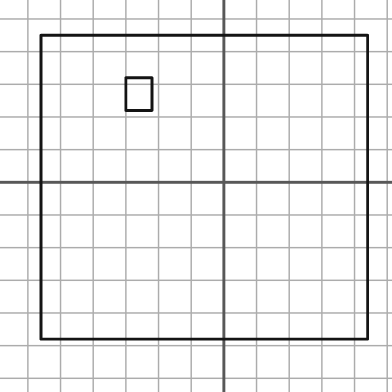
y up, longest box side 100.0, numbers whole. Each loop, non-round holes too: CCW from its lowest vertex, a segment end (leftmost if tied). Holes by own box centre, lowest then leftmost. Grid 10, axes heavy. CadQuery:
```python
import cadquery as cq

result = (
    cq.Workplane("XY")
    .moveTo(-56.0, -48.0)
    .lineTo(44.0, -48.0)
    .lineTo(44.0, 45.0)
    .lineTo(-56.0, 45.0)
    .close()
    .moveTo(-30.0, 22.0)
    .lineTo(-22.0, 22.0)
    .lineTo(-22.0, 32.0)
    .lineTo(-30.0, 32.0)
    .close()
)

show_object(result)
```